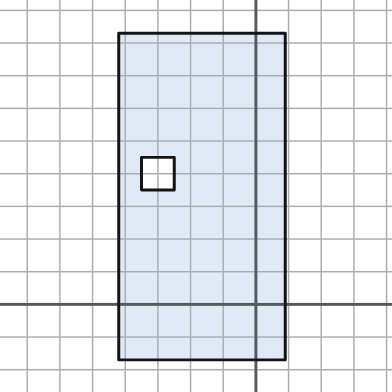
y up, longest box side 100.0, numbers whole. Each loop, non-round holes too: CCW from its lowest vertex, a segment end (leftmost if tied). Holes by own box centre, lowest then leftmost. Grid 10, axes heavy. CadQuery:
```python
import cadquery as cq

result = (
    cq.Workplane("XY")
    .moveTo(-42.0, -17.0)
    .lineTo(9.0, -17.0)
    .lineTo(9.0, 83.0)
    .lineTo(-42.0, 83.0)
    .close()
    .moveTo(-35.0, 35.0)
    .lineTo(-25.0, 35.0)
    .lineTo(-25.0, 45.0)
    .lineTo(-35.0, 45.0)
    .close()
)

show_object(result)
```